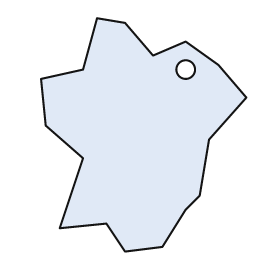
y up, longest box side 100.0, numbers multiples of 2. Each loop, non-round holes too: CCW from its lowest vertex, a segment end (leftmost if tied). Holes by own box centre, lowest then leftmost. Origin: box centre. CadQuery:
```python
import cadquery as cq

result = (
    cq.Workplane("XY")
    .moveTo(-8.0, -50.0)
    .lineTo(8.0, -48.0)
    .lineTo(18.0, -32.0)
    .lineTo(24.0, -26.0)
    .lineTo(28.0, -2.0)
    .lineTo(44.0, 16.0)
    .lineTo(32.0, 30.0)
    .lineTo(18.0, 40.0)
    .lineTo(4.0, 34.0)
    .lineTo(-8.0, 48.0)
    .lineTo(-20.0, 50.0)
    .lineTo(-26.0, 28.0)
    .lineTo(-44.0, 24.0)
    .lineTo(-42.0, 4.0)
    .lineTo(-26.0, -10.0)
    .lineTo(-36.0, -40.0)
    .lineTo(-16.0, -38.0)
    .close()
    .moveTo(18.0, 28.0)
    .circle(4.0)
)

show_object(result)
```